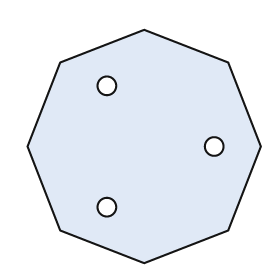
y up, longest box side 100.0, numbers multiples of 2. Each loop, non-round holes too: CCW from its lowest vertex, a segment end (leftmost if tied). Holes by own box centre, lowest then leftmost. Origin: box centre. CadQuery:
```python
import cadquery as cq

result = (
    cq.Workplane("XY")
    .moveTo(0.0, -50.0)
    .lineTo(36.0, -36.0)
    .lineTo(50.0, 0.0)
    .lineTo(36.0, 36.0)
    .lineTo(0.0, 50.0)
    .lineTo(-36.0, 36.0)
    .lineTo(-50.0, 0.0)
    .lineTo(-36.0, -36.0)
    .close()
    .moveTo(-16.0, -26.0)
    .circle(4.0)
    .moveTo(30.0, 0.0)
    .circle(4.0)
    .moveTo(-16.0, 26.0)
    .circle(4.0)
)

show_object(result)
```